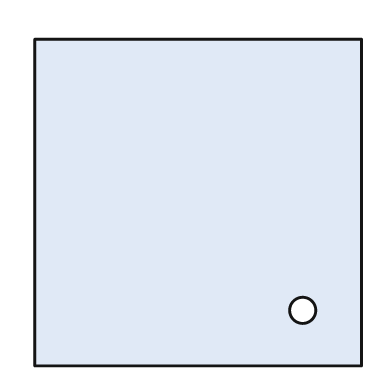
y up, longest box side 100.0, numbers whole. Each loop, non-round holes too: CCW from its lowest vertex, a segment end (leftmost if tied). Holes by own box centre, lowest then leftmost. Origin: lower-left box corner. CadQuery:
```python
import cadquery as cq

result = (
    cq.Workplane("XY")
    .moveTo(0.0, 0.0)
    .lineTo(100.0, 0.0)
    .lineTo(100.0, 100.0)
    .lineTo(0.0, 100.0)
    .close()
    .moveTo(82.0, 17.0)
    .circle(4.0)
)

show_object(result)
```